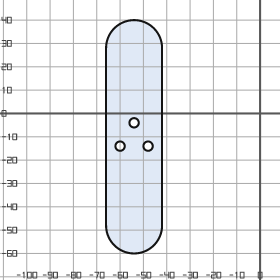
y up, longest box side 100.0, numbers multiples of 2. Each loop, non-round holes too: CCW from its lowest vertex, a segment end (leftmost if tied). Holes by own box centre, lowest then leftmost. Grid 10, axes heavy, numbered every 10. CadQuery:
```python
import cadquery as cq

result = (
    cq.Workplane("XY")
    .moveTo(-66.0, -48.0)
    .threePointArc((-54.0, -60.0), (-42.0, -48.0))
    .lineTo(-42.0, 28.0)
    .threePointArc((-54.0, 40.0), (-66.0, 28.0))
    .close()
    .moveTo(-60.0, -14.0)
    .circle(2.0)
    .moveTo(-48.0, -14.0)
    .circle(2.0)
    .moveTo(-54.0, -4.0)
    .circle(2.0)
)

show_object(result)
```